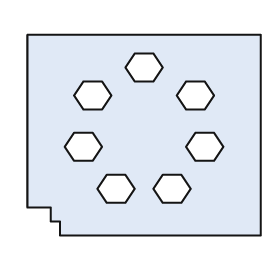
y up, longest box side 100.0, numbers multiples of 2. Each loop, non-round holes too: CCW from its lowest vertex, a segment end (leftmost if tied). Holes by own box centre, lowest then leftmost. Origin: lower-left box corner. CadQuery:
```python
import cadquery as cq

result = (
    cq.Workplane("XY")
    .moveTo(14.0, 0.0)
    .lineTo(100.0, 0.0)
    .lineTo(100.0, 86.0)
    .lineTo(0.0, 86.0)
    .lineTo(0.0, 12.0)
    .lineTo(10.0, 12.0)
    .lineTo(10.0, 6.0)
    .lineTo(14.0, 6.0)
    .close()
    .moveTo(34.0, 14.0)
    .lineTo(42.0, 14.0)
    .lineTo(46.0, 20.0)
    .lineTo(42.0, 26.0)
    .lineTo(34.0, 26.0)
    .lineTo(30.0, 20.0)
    .close()
    .moveTo(58.0, 14.0)
    .lineTo(66.0, 14.0)
    .lineTo(70.0, 20.0)
    .lineTo(66.0, 26.0)
    .lineTo(58.0, 26.0)
    .lineTo(54.0, 20.0)
    .close()
    .moveTo(20.0, 32.0)
    .lineTo(28.0, 32.0)
    .lineTo(32.0, 38.0)
    .lineTo(28.0, 44.0)
    .lineTo(20.0, 44.0)
    .lineTo(16.0, 38.0)
    .close()
    .moveTo(72.0, 32.0)
    .lineTo(80.0, 32.0)
    .lineTo(84.0, 38.0)
    .lineTo(80.0, 44.0)
    .lineTo(72.0, 44.0)
    .lineTo(68.0, 38.0)
    .close()
    .moveTo(24.0, 54.0)
    .lineTo(32.0, 54.0)
    .lineTo(36.0, 60.0)
    .lineTo(32.0, 66.0)
    .lineTo(24.0, 66.0)
    .lineTo(20.0, 60.0)
    .close()
    .moveTo(68.0, 54.0)
    .lineTo(76.0, 54.0)
    .lineTo(80.0, 60.0)
    .lineTo(76.0, 66.0)
    .lineTo(68.0, 66.0)
    .lineTo(64.0, 60.0)
    .close()
    .moveTo(46.0, 66.0)
    .lineTo(54.0, 66.0)
    .lineTo(58.0, 72.0)
    .lineTo(54.0, 78.0)
    .lineTo(46.0, 78.0)
    .lineTo(42.0, 72.0)
    .close()
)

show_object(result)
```